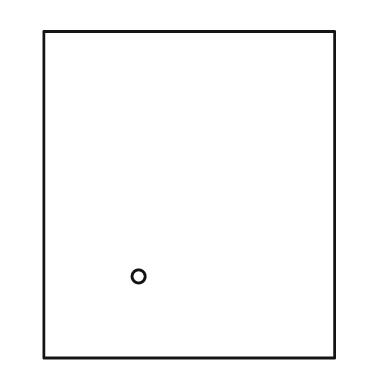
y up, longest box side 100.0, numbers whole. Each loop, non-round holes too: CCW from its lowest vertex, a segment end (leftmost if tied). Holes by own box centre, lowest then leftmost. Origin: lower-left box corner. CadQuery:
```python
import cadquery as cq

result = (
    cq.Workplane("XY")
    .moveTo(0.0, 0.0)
    .lineTo(89.0, 0.0)
    .lineTo(89.0, 100.0)
    .lineTo(0.0, 100.0)
    .close()
    .moveTo(29.0, 25.0)
    .circle(2.0)
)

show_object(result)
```